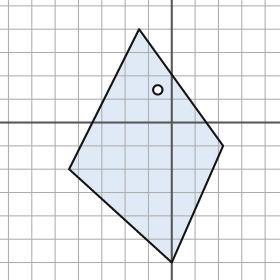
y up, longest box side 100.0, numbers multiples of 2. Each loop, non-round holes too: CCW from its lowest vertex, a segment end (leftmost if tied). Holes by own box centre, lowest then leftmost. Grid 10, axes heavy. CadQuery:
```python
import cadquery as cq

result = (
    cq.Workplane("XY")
    .moveTo(0.0, -60.0)
    .lineTo(22.0, -10.0)
    .lineTo(-14.0, 40.0)
    .lineTo(-44.0, -20.0)
    .close()
    .moveTo(-6.0, 14.0)
    .circle(2.0)
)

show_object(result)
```